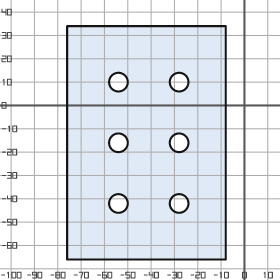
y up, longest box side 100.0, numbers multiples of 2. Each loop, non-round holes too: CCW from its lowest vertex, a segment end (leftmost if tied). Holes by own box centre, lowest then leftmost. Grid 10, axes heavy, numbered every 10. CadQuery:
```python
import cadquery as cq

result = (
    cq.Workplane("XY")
    .moveTo(-76.0, -66.0)
    .lineTo(-8.0, -66.0)
    .lineTo(-8.0, 34.0)
    .lineTo(-76.0, 34.0)
    .close()
    .moveTo(-54.0, -42.0)
    .circle(4.0)
    .moveTo(-28.0, -42.0)
    .circle(4.0)
    .moveTo(-54.0, -16.0)
    .circle(4.0)
    .moveTo(-28.0, -16.0)
    .circle(4.0)
    .moveTo(-54.0, 10.0)
    .circle(4.0)
    .moveTo(-28.0, 10.0)
    .circle(4.0)
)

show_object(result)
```